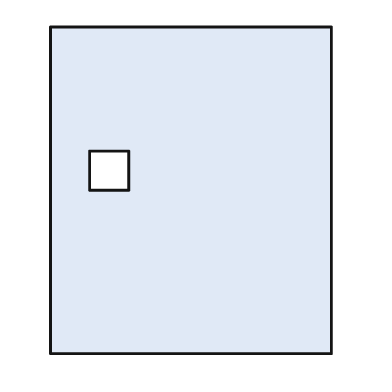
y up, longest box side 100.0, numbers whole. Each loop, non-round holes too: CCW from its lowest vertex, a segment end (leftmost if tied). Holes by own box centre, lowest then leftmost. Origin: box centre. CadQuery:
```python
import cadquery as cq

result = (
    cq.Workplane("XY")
    .moveTo(-43.0, -50.0)
    .lineTo(43.0, -50.0)
    .lineTo(43.0, 50.0)
    .lineTo(-43.0, 50.0)
    .close()
    .moveTo(-31.0, 0.0)
    .lineTo(-19.0, 0.0)
    .lineTo(-19.0, 12.0)
    .lineTo(-31.0, 12.0)
    .close()
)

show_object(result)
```